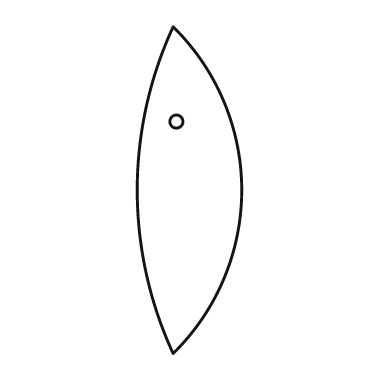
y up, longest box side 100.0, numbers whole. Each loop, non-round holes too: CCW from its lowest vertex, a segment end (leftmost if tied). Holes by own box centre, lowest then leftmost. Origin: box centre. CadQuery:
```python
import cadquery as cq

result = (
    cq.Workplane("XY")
    .moveTo(-5.0, -50.0)
    .threePointArc((16.0, 0.0), (-5.0, 50.0))
    .threePointArc((-16.0, 0.0), (-5.0, -50.0))
    .close()
    .moveTo(-4.0, 21.0)
    .circle(2.0)
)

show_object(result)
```